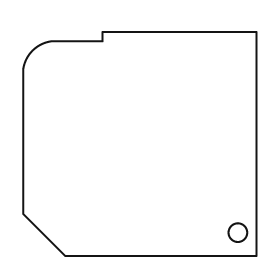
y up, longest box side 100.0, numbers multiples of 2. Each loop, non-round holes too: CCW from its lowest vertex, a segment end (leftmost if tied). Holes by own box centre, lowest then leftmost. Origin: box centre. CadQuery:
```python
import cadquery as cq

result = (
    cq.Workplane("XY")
    .moveTo(-32.0, -48.0)
    .lineTo(50.0, -48.0)
    .lineTo(50.0, 48.0)
    .lineTo(-16.0, 48.0)
    .lineTo(-16.0, 44.0)
    .lineTo(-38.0, 44.0)
    .threePointArc((-46.0, 40.0), (-50.0, 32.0))
    .lineTo(-50.0, -30.0)
    .close()
    .moveTo(42.0, -38.0)
    .circle(4.0)
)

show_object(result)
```